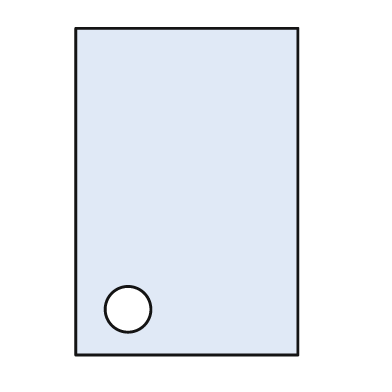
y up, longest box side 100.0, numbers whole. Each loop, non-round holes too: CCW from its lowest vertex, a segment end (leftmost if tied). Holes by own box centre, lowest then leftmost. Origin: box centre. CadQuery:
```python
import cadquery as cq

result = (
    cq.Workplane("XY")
    .moveTo(-34.0, -50.0)
    .lineTo(34.0, -50.0)
    .lineTo(34.0, 50.0)
    .lineTo(-34.0, 50.0)
    .close()
    .moveTo(-18.0, -36.0)
    .circle(7.0)
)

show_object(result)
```